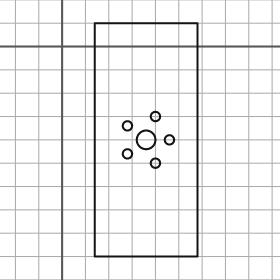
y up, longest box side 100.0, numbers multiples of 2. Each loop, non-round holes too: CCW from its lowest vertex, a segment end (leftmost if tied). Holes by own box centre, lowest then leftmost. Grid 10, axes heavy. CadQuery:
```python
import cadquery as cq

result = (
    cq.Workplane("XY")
    .moveTo(14.0, -90.0)
    .lineTo(58.0, -90.0)
    .lineTo(58.0, 10.0)
    .lineTo(14.0, 10.0)
    .close()
    .moveTo(40.0, -50.0)
    .circle(2.0)
    .moveTo(28.0, -46.0)
    .circle(2.0)
    .moveTo(36.0, -40.0)
    .circle(4.0)
    .moveTo(46.0, -40.0)
    .circle(2.0)
    .moveTo(28.0, -34.0)
    .circle(2.0)
    .moveTo(40.0, -30.0)
    .circle(2.0)
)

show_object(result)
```